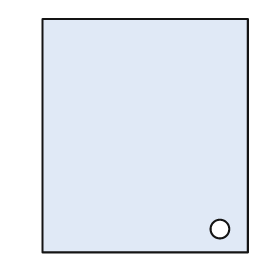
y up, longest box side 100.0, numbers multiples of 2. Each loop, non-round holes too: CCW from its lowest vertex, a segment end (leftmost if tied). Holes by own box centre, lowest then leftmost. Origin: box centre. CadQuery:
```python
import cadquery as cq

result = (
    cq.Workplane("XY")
    .moveTo(-44.0, -50.0)
    .lineTo(44.0, -50.0)
    .lineTo(44.0, 50.0)
    .lineTo(-44.0, 50.0)
    .close()
    .moveTo(32.0, -40.0)
    .circle(4.0)
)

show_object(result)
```